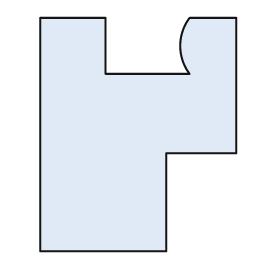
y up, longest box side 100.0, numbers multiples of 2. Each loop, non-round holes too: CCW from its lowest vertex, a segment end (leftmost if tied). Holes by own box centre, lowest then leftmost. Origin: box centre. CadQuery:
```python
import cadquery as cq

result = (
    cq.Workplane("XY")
    .moveTo(-42.0, -50.0)
    .lineTo(12.0, -50.0)
    .lineTo(12.0, -8.0)
    .lineTo(42.0, -8.0)
    .lineTo(42.0, 50.0)
    .lineTo(22.0, 50.0)
    .threePointArc((18.0, 38.0), (22.0, 26.0))
    .lineTo(-14.0, 26.0)
    .lineTo(-14.0, 50.0)
    .lineTo(-42.0, 50.0)
    .close()
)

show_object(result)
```